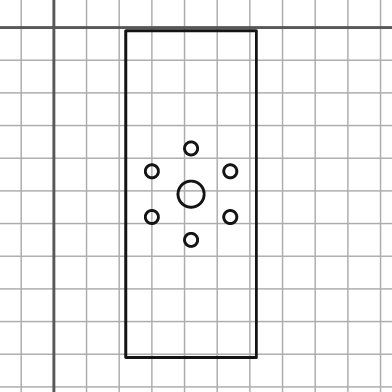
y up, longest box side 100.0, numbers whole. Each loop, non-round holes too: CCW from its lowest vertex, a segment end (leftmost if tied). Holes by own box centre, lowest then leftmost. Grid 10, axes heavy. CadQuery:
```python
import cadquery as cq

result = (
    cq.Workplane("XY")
    .moveTo(22.0, -101.0)
    .lineTo(62.0, -101.0)
    .lineTo(62.0, -1.0)
    .lineTo(22.0, -1.0)
    .close()
    .moveTo(42.0, -65.0)
    .circle(2.0)
    .moveTo(30.0, -58.0)
    .circle(2.0)
    .moveTo(54.0, -58.0)
    .circle(2.0)
    .moveTo(42.0, -51.0)
    .circle(4.0)
    .moveTo(30.0, -44.0)
    .circle(2.0)
    .moveTo(54.0, -44.0)
    .circle(2.0)
    .moveTo(42.0, -37.0)
    .circle(2.0)
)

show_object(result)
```